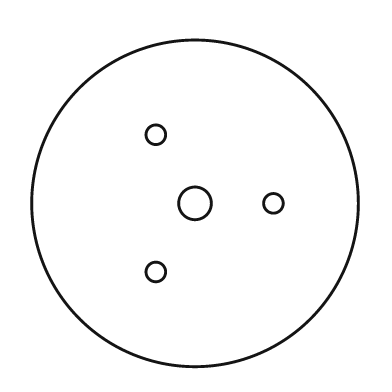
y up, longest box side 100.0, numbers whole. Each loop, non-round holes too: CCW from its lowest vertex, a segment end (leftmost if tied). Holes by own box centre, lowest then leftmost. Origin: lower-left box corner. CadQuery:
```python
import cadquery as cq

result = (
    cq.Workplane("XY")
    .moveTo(50.0, 50.0)
    .circle(50.0)
    .moveTo(38.0, 29.0)
    .circle(3.0)
    .moveTo(50.0, 50.0)
    .circle(5.0)
    .moveTo(74.0, 50.0)
    .circle(3.0)
    .moveTo(38.0, 71.0)
    .circle(3.0)
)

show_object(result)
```